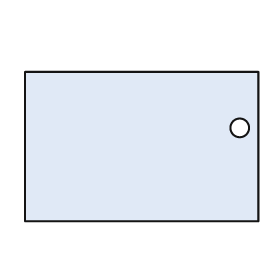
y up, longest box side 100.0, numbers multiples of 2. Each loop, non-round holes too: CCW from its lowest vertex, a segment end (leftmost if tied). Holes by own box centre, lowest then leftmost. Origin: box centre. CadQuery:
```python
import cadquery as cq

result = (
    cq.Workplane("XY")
    .moveTo(-50.0, -32.0)
    .lineTo(50.0, -32.0)
    .lineTo(50.0, 32.0)
    .lineTo(-50.0, 32.0)
    .close()
    .moveTo(42.0, 8.0)
    .circle(4.0)
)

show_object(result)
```